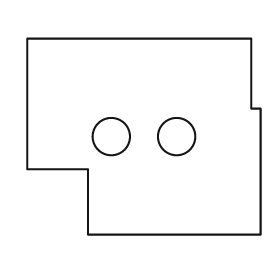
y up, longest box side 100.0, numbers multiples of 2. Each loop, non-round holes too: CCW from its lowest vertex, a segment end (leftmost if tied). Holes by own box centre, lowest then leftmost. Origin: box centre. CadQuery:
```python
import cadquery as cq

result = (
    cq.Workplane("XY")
    .moveTo(-24.0, -42.0)
    .lineTo(50.0, -42.0)
    .lineTo(50.0, 12.0)
    .lineTo(46.0, 12.0)
    .lineTo(46.0, 42.0)
    .lineTo(-50.0, 42.0)
    .lineTo(-50.0, -14.0)
    .lineTo(-24.0, -14.0)
    .close()
    .moveTo(-14.0, 0.0)
    .circle(8.0)
    .moveTo(14.0, 0.0)
    .circle(8.0)
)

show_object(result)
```